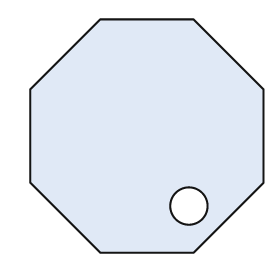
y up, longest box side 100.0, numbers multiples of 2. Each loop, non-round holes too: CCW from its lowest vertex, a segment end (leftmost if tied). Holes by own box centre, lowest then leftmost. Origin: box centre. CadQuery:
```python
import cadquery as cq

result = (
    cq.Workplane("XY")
    .moveTo(-20.0, -50.0)
    .lineTo(20.0, -50.0)
    .lineTo(50.0, -20.0)
    .lineTo(50.0, 20.0)
    .lineTo(20.0, 50.0)
    .lineTo(-20.0, 50.0)
    .lineTo(-50.0, 20.0)
    .lineTo(-50.0, -20.0)
    .close()
    .moveTo(18.0, -30.0)
    .circle(8.0)
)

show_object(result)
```